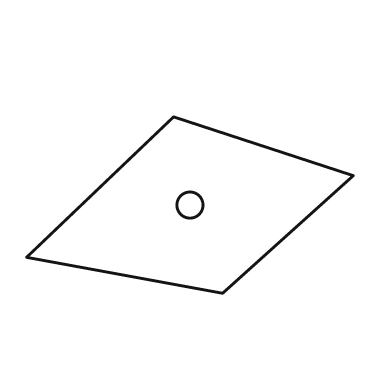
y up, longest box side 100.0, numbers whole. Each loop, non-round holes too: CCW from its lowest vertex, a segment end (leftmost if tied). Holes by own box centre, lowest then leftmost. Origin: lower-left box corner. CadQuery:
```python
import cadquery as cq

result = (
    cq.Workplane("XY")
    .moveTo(60.0, 0.0)
    .lineTo(100.0, 36.0)
    .lineTo(45.0, 54.0)
    .lineTo(0.0, 11.0)
    .close()
    .moveTo(50.0, 27.0)
    .circle(4.0)
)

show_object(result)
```